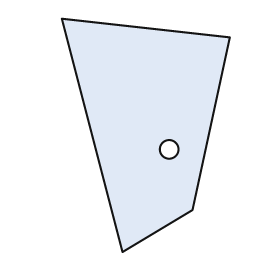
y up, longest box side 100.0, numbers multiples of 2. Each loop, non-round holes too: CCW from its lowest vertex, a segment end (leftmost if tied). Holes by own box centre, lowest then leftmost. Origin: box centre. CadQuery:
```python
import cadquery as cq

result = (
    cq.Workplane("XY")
    .moveTo(-10.0, -50.0)
    .lineTo(20.0, -32.0)
    .lineTo(36.0, 42.0)
    .lineTo(-36.0, 50.0)
    .close()
    .moveTo(10.0, -6.0)
    .circle(4.0)
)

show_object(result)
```